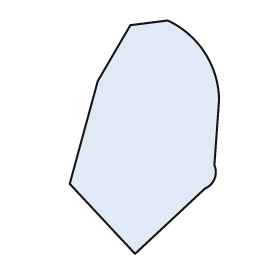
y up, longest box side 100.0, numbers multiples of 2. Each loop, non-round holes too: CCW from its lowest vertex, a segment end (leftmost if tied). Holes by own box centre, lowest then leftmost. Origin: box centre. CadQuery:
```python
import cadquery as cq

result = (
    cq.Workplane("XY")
    .moveTo(-4.0, -50.0)
    .lineTo(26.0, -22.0)
    .threePointArc((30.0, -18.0), (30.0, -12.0))
    .lineTo(32.0, 16.0)
    .threePointArc((26.0, 36.0), (10.0, 50.0))
    .lineTo(-6.0, 48.0)
    .lineTo(-20.0, 24.0)
    .lineTo(-32.0, -20.0)
    .close()
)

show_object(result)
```